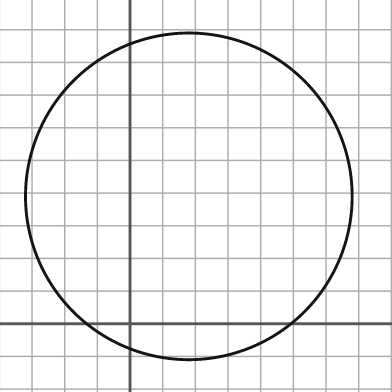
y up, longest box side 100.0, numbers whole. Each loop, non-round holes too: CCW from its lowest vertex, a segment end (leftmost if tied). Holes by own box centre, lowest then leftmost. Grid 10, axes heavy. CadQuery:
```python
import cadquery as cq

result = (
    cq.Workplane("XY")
    .moveTo(18.0, 39.0)
    .circle(50.0)
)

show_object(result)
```